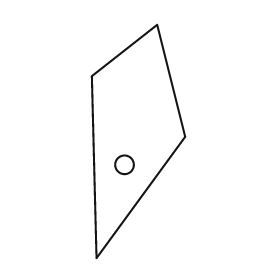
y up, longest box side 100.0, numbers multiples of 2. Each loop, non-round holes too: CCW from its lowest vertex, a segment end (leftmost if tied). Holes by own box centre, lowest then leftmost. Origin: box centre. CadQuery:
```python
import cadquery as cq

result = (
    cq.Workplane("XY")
    .moveTo(-18.0, -50.0)
    .lineTo(20.0, 2.0)
    .lineTo(8.0, 50.0)
    .lineTo(-20.0, 28.0)
    .close()
    .moveTo(-6.0, -10.0)
    .circle(4.0)
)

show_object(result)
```